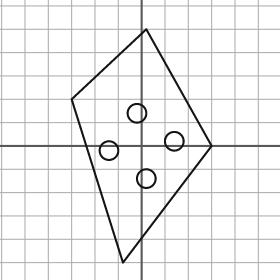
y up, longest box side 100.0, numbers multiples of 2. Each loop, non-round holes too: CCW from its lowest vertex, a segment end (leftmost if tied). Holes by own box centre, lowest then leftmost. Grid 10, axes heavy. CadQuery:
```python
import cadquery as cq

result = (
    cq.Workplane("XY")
    .moveTo(-8.0, -50.0)
    .lineTo(30.0, 0.0)
    .lineTo(2.0, 50.0)
    .lineTo(-30.0, 20.0)
    .close()
    .moveTo(2.0, -14.0)
    .circle(4.0)
    .moveTo(-14.0, -2.0)
    .circle(4.0)
    .moveTo(14.0, 2.0)
    .circle(4.0)
    .moveTo(-2.0, 14.0)
    .circle(4.0)
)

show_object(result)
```